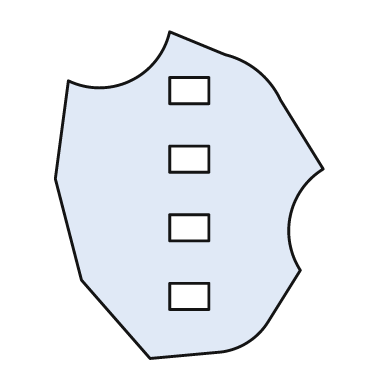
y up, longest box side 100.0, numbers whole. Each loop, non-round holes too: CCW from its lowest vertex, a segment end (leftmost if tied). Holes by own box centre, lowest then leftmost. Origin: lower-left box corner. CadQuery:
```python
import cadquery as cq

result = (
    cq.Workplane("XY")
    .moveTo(29.0, 0.0)
    .lineTo(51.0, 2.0)
    .threePointArc((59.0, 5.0), (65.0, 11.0))
    .lineTo(75.0, 27.0)
    .threePointArc((72.0, 44.0), (82.0, 58.0))
    .lineTo(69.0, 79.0)
    .threePointArc((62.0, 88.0), (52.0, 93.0))
    .lineTo(35.0, 100.0)
    .threePointArc((23.0, 85.0), (4.0, 85.0))
    .lineTo(0.0, 55.0)
    .lineTo(8.0, 24.0)
    .close()
    .moveTo(35.0, 15.0)
    .lineTo(47.0, 15.0)
    .lineTo(47.0, 23.0)
    .lineTo(35.0, 23.0)
    .close()
    .moveTo(35.0, 36.0)
    .lineTo(47.0, 36.0)
    .lineTo(47.0, 44.0)
    .lineTo(35.0, 44.0)
    .close()
    .moveTo(35.0, 57.0)
    .lineTo(47.0, 57.0)
    .lineTo(47.0, 65.0)
    .lineTo(35.0, 65.0)
    .close()
    .moveTo(35.0, 78.0)
    .lineTo(47.0, 78.0)
    .lineTo(47.0, 86.0)
    .lineTo(35.0, 86.0)
    .close()
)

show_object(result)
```